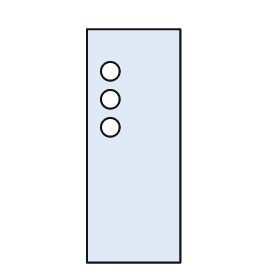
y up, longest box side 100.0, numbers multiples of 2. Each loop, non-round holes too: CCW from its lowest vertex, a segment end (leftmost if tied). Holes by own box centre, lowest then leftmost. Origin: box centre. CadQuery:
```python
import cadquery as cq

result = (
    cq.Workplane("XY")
    .moveTo(-20.0, -50.0)
    .lineTo(20.0, -50.0)
    .lineTo(20.0, 50.0)
    .lineTo(-20.0, 50.0)
    .close()
    .moveTo(-10.0, 8.0)
    .circle(4.0)
    .moveTo(-10.0, 20.0)
    .circle(4.0)
    .moveTo(-10.0, 32.0)
    .circle(4.0)
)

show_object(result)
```